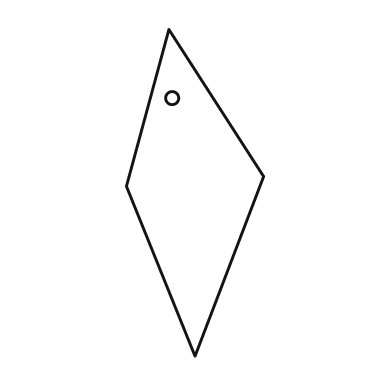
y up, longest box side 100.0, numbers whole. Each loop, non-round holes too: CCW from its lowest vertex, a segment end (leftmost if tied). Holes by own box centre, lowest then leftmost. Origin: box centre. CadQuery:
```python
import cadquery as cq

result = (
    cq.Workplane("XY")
    .moveTo(0.0, -50.0)
    .lineTo(21.0, 5.0)
    .lineTo(-8.0, 50.0)
    .lineTo(-21.0, 2.0)
    .close()
    .moveTo(-7.0, 29.0)
    .circle(2.0)
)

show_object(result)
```